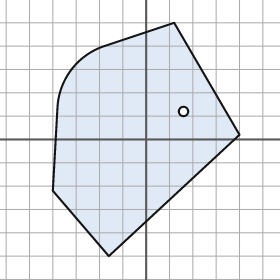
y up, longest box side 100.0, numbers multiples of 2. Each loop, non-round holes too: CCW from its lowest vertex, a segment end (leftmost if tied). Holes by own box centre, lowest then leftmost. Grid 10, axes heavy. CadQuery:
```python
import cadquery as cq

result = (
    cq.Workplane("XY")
    .moveTo(-16.0, -50.0)
    .lineTo(40.0, 2.0)
    .lineTo(12.0, 50.0)
    .lineTo(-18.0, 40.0)
    .threePointArc((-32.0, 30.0), (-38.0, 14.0))
    .lineTo(-40.0, -22.0)
    .close()
    .moveTo(16.0, 12.0)
    .circle(2.0)
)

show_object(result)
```